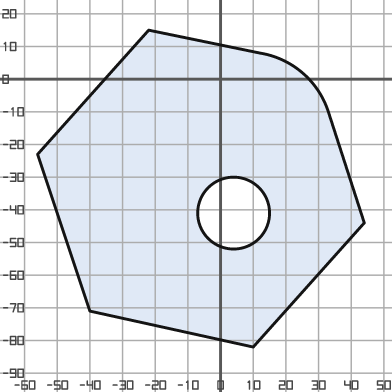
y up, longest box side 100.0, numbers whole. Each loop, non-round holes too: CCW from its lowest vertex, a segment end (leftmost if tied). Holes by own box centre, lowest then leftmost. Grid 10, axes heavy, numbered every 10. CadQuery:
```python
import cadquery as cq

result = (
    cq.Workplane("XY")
    .moveTo(10.0, -82.0)
    .lineTo(44.0, -44.0)
    .lineTo(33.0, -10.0)
    .threePointArc((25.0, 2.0), (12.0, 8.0))
    .lineTo(-22.0, 15.0)
    .lineTo(-56.0, -23.0)
    .lineTo(-40.0, -71.0)
    .close()
    .moveTo(4.0, -41.0)
    .circle(11.0)
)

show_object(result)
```